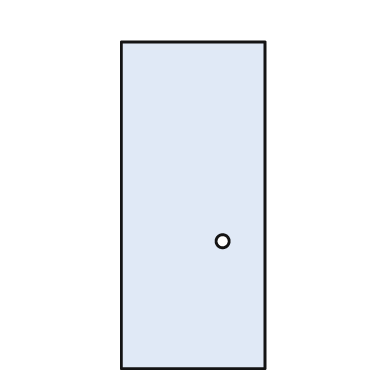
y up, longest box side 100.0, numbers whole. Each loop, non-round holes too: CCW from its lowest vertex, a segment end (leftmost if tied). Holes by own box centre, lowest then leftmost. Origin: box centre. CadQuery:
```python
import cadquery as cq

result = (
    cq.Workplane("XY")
    .moveTo(-22.0, -50.0)
    .lineTo(22.0, -50.0)
    .lineTo(22.0, 50.0)
    .lineTo(-22.0, 50.0)
    .close()
    .moveTo(9.0, -11.0)
    .circle(2.0)
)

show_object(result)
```